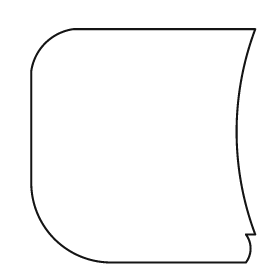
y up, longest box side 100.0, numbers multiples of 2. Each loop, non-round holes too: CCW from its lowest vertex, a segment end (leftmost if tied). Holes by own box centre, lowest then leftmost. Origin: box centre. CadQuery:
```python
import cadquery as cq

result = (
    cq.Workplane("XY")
    .moveTo(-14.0, -50.0)
    .lineTo(44.0, -50.0)
    .threePointArc((46.0, -44.0), (44.0, -38.0))
    .lineTo(48.0, -38.0)
    .threePointArc((40.0, 6.0), (48.0, 50.0))
    .lineTo(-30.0, 50.0)
    .threePointArc((-42.0, 44.0), (-48.0, 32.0))
    .lineTo(-48.0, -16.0)
    .threePointArc((-38.0, -40.0), (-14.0, -50.0))
    .close()
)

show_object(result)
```